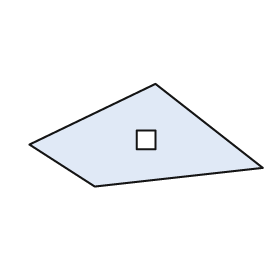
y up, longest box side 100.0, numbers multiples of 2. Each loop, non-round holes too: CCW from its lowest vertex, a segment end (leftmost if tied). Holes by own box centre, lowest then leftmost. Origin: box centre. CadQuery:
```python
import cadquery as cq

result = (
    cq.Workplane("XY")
    .moveTo(-22.0, -22.0)
    .lineTo(50.0, -14.0)
    .lineTo(4.0, 22.0)
    .lineTo(-50.0, -4.0)
    .close()
    .moveTo(-4.0, -6.0)
    .lineTo(4.0, -6.0)
    .lineTo(4.0, 2.0)
    .lineTo(-4.0, 2.0)
    .close()
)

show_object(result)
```